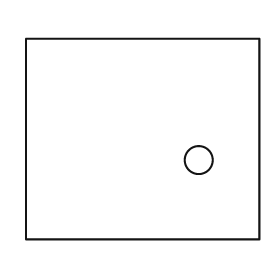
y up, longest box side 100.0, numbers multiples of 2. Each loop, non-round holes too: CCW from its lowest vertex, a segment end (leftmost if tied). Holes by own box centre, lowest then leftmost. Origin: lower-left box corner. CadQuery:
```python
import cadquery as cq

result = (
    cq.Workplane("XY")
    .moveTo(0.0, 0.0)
    .lineTo(100.0, 0.0)
    .lineTo(100.0, 86.0)
    .lineTo(0.0, 86.0)
    .close()
    .moveTo(74.0, 34.0)
    .circle(6.0)
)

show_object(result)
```